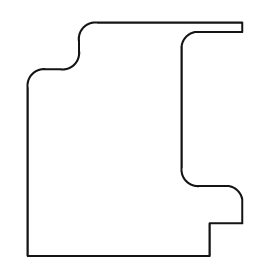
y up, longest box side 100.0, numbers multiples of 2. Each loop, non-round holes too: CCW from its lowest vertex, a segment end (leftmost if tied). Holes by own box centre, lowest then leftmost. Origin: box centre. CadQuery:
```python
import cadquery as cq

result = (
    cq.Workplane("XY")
    .moveTo(-46.0, -50.0)
    .lineTo(32.0, -50.0)
    .lineTo(32.0, -36.0)
    .lineTo(46.0, -36.0)
    .lineTo(46.0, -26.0)
    .threePointArc((44.0, -22.0), (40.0, -20.0))
    .lineTo(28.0, -20.0)
    .threePointArc((22.0, -18.0), (20.0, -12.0))
    .lineTo(20.0, 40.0)
    .threePointArc((22.0, 44.0), (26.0, 46.0))
    .lineTo(46.0, 46.0)
    .lineTo(46.0, 50.0)
    .lineTo(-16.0, 50.0)
    .threePointArc((-22.0, 48.0), (-24.0, 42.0))
    .lineTo(-24.0, 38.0)
    .threePointArc((-26.0, 32.0), (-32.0, 30.0))
    .lineTo(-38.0, 30.0)
    .threePointArc((-44.0, 28.0), (-46.0, 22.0))
    .close()
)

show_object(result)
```